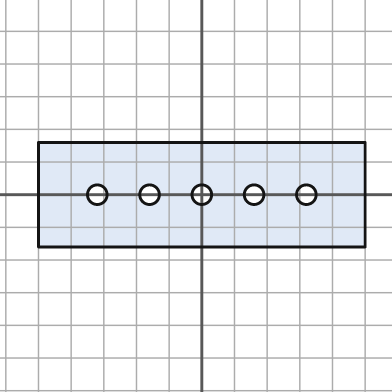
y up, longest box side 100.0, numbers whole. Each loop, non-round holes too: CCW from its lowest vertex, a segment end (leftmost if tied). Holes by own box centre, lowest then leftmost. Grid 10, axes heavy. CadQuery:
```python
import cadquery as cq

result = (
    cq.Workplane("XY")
    .moveTo(-50.0, -16.0)
    .lineTo(50.0, -16.0)
    .lineTo(50.0, 16.0)
    .lineTo(-50.0, 16.0)
    .close()
    .moveTo(-32.0, 0.0)
    .circle(3.0)
    .moveTo(-16.0, 0.0)
    .circle(3.0)
    .moveTo(0.0, 0.0)
    .circle(3.0)
    .moveTo(16.0, 0.0)
    .circle(3.0)
    .moveTo(32.0, 0.0)
    .circle(3.0)
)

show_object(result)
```